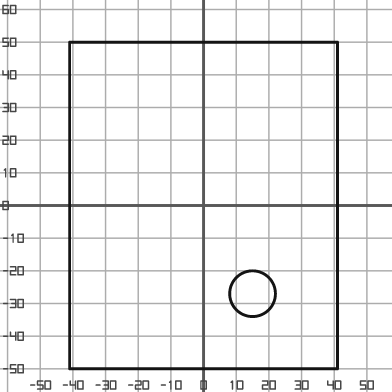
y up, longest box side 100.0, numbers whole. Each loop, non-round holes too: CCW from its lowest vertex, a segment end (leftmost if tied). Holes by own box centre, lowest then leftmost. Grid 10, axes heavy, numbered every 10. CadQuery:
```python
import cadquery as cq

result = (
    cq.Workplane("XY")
    .moveTo(-41.0, -50.0)
    .lineTo(41.0, -50.0)
    .lineTo(41.0, 50.0)
    .lineTo(-41.0, 50.0)
    .close()
    .moveTo(15.0, -27.0)
    .circle(7.0)
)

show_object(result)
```